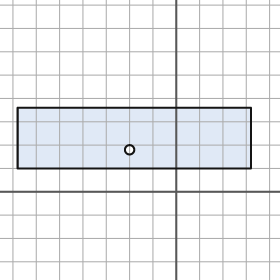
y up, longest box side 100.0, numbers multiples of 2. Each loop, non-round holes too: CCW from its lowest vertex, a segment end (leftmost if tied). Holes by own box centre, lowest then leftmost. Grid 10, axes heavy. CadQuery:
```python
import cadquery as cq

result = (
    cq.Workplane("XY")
    .moveTo(-68.0, 10.0)
    .lineTo(32.0, 10.0)
    .lineTo(32.0, 36.0)
    .lineTo(-68.0, 36.0)
    .close()
    .moveTo(-20.0, 18.0)
    .circle(2.0)
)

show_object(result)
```